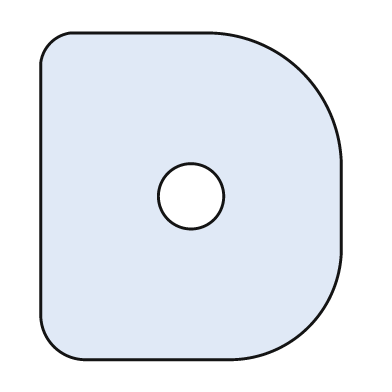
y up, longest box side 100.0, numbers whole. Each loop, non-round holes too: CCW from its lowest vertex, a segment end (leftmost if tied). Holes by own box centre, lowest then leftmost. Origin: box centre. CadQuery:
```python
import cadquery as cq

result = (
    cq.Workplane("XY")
    .moveTo(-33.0, -50.0)
    .lineTo(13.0, -50.0)
    .threePointArc((36.0, -40.0), (46.0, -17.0))
    .lineTo(46.0, 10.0)
    .threePointArc((34.0, 38.0), (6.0, 50.0))
    .lineTo(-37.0, 50.0)
    .threePointArc((-43.0, 47.0), (-46.0, 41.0))
    .lineTo(-46.0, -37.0)
    .threePointArc((-42.0, -46.0), (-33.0, -50.0))
    .close()
    .moveTo(0.0, 0.0)
    .circle(10.0)
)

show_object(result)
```